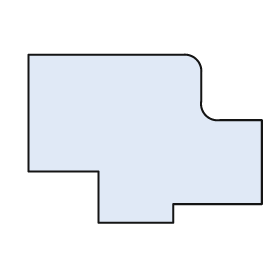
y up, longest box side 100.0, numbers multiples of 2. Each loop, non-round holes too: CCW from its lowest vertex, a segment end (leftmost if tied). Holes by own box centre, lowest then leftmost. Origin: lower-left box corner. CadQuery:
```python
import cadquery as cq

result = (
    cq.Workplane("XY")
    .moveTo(30.0, 0.0)
    .lineTo(62.0, 0.0)
    .lineTo(62.0, 8.0)
    .lineTo(100.0, 8.0)
    .lineTo(100.0, 44.0)
    .lineTo(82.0, 44.0)
    .threePointArc((76.0, 46.0), (74.0, 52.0))
    .lineTo(74.0, 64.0)
    .threePointArc((72.0, 70.0), (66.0, 72.0))
    .lineTo(0.0, 72.0)
    .lineTo(0.0, 22.0)
    .lineTo(30.0, 22.0)
    .close()
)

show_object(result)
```